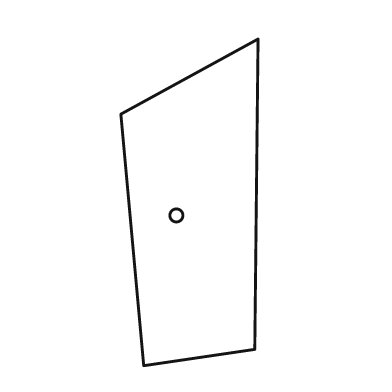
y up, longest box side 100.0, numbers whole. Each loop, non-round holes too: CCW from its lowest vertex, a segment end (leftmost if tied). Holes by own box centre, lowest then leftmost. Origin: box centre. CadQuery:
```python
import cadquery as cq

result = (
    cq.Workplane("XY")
    .moveTo(-14.0, -50.0)
    .lineTo(20.0, -45.0)
    .lineTo(21.0, 50.0)
    .lineTo(-21.0, 27.0)
    .close()
    .moveTo(-4.0, -4.0)
    .circle(2.0)
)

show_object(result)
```